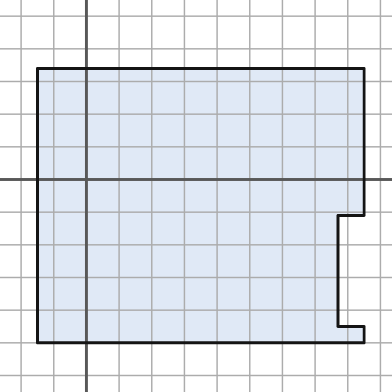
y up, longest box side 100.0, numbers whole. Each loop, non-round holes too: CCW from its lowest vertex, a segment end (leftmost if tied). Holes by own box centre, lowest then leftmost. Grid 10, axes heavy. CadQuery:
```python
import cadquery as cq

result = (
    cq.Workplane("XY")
    .moveTo(-15.0, -50.0)
    .lineTo(85.0, -50.0)
    .lineTo(85.0, -45.0)
    .lineTo(77.0, -45.0)
    .lineTo(77.0, -11.0)
    .lineTo(85.0, -11.0)
    .lineTo(85.0, 34.0)
    .lineTo(-15.0, 34.0)
    .close()
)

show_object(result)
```